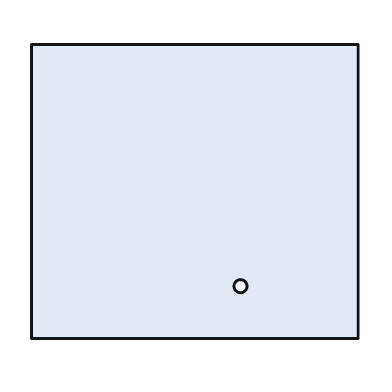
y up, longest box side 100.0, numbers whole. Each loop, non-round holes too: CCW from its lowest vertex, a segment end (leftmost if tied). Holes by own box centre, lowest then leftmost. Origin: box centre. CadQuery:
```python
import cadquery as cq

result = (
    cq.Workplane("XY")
    .moveTo(-50.0, -45.0)
    .lineTo(50.0, -45.0)
    .lineTo(50.0, 45.0)
    .lineTo(-50.0, 45.0)
    .close()
    .moveTo(14.0, -29.0)
    .circle(2.0)
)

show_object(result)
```